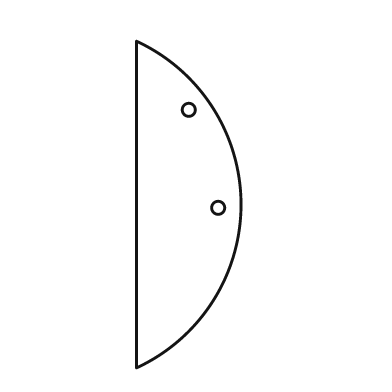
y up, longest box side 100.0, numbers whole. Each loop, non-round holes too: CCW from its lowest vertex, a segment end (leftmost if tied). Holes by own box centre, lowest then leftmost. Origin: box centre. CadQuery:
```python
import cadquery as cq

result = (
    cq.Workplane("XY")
    .moveTo(-16.0, -50.0)
    .threePointArc((16.0, 0.0), (-16.0, 50.0))
    .close()
    .moveTo(9.0, -1.0)
    .circle(2.0)
    .moveTo(0.0, 29.0)
    .circle(2.0)
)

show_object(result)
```